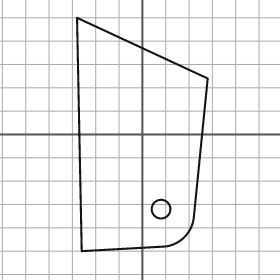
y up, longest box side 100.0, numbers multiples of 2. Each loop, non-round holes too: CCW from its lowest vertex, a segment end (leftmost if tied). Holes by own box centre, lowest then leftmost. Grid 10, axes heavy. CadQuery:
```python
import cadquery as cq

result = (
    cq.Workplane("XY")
    .moveTo(-26.0, -50.0)
    .lineTo(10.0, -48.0)
    .threePointArc((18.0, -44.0), (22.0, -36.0))
    .lineTo(28.0, 24.0)
    .lineTo(-28.0, 50.0)
    .close()
    .moveTo(8.0, -32.0)
    .circle(4.0)
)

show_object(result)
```